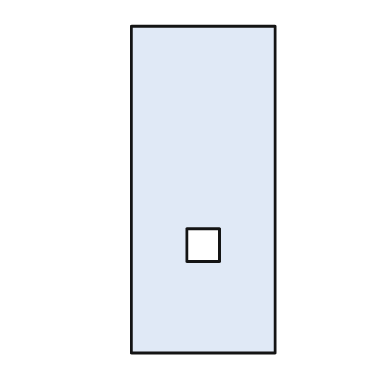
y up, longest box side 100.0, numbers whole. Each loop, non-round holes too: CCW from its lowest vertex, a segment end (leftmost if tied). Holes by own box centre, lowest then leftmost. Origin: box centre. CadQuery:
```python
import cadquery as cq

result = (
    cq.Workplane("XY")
    .moveTo(-22.0, -50.0)
    .lineTo(22.0, -50.0)
    .lineTo(22.0, 50.0)
    .lineTo(-22.0, 50.0)
    .close()
    .moveTo(-5.0, -22.0)
    .lineTo(5.0, -22.0)
    .lineTo(5.0, -12.0)
    .lineTo(-5.0, -12.0)
    .close()
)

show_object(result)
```